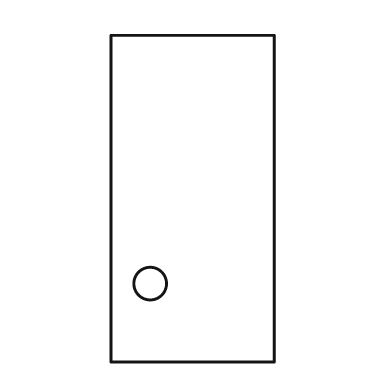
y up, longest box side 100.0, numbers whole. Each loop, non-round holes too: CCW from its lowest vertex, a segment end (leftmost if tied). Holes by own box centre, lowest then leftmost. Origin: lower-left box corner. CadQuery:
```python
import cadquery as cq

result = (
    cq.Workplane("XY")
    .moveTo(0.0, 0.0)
    .lineTo(50.0, 0.0)
    .lineTo(50.0, 100.0)
    .lineTo(0.0, 100.0)
    .close()
    .moveTo(12.0, 24.0)
    .circle(5.0)
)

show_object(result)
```